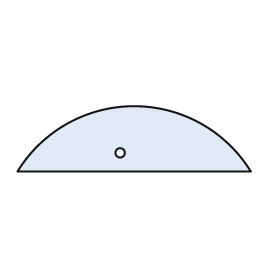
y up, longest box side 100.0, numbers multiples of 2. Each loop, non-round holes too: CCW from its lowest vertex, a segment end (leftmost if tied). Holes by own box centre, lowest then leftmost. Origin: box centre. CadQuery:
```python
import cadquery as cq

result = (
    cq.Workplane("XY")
    .moveTo(-50.0, -14.0)
    .lineTo(50.0, -14.0)
    .threePointArc((0.0, 14.0), (-50.0, -14.0))
    .close()
    .moveTo(-6.0, -6.0)
    .circle(2.0)
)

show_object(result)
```